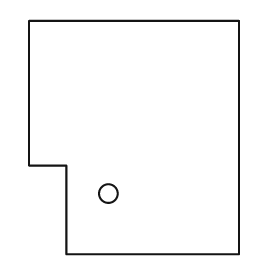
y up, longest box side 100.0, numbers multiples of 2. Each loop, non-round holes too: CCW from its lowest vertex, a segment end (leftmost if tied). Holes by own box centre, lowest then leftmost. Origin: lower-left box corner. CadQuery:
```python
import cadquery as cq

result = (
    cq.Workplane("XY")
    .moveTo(16.0, 0.0)
    .lineTo(90.0, 0.0)
    .lineTo(90.0, 100.0)
    .lineTo(0.0, 100.0)
    .lineTo(0.0, 38.0)
    .lineTo(16.0, 38.0)
    .close()
    .moveTo(34.0, 26.0)
    .circle(4.0)
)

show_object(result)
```